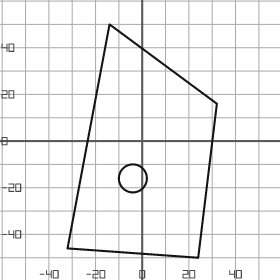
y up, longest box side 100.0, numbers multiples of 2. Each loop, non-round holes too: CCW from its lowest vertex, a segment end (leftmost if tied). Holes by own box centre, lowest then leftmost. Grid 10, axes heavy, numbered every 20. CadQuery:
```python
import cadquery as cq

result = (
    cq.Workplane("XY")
    .moveTo(24.0, -50.0)
    .lineTo(32.0, 16.0)
    .lineTo(-14.0, 50.0)
    .lineTo(-32.0, -46.0)
    .close()
    .moveTo(-4.0, -16.0)
    .circle(6.0)
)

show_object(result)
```